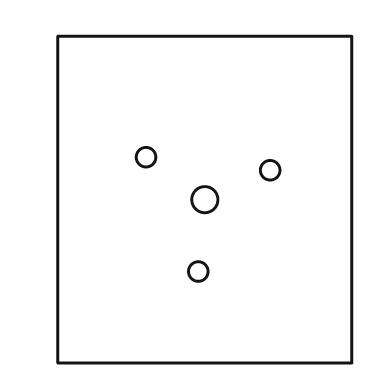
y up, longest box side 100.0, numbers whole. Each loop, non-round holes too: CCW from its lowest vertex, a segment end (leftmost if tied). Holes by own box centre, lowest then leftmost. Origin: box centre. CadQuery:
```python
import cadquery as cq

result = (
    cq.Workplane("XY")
    .moveTo(-45.0, -50.0)
    .lineTo(45.0, -50.0)
    .lineTo(45.0, 50.0)
    .lineTo(-45.0, 50.0)
    .close()
    .moveTo(-2.0, -22.0)
    .circle(3.0)
    .moveTo(0.0, 0.0)
    .circle(4.0)
    .moveTo(20.0, 9.0)
    .circle(3.0)
    .moveTo(-18.0, 13.0)
    .circle(3.0)
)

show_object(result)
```